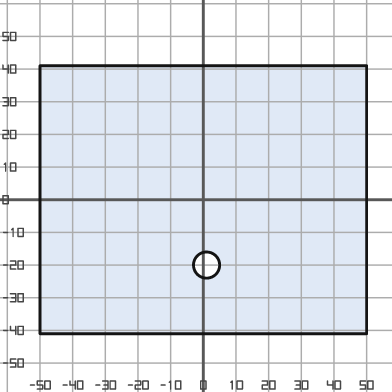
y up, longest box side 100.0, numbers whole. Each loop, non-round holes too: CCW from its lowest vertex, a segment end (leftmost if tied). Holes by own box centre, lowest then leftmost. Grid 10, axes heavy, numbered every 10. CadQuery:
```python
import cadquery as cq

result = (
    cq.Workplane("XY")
    .moveTo(-50.0, -41.0)
    .lineTo(50.0, -41.0)
    .lineTo(50.0, 41.0)
    .lineTo(-50.0, 41.0)
    .close()
    .moveTo(1.0, -20.0)
    .circle(4.0)
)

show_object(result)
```